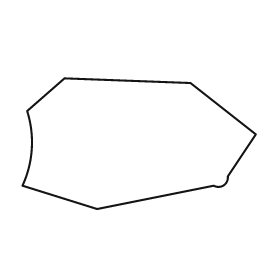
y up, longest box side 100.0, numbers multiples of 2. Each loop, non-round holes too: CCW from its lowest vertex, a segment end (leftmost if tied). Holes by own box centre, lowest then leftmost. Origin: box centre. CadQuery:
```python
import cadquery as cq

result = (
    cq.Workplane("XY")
    .moveTo(-18.0, -28.0)
    .lineTo(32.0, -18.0)
    .threePointArc((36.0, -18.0), (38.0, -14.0))
    .lineTo(50.0, 4.0)
    .lineTo(22.0, 26.0)
    .lineTo(-32.0, 28.0)
    .lineTo(-48.0, 14.0)
    .threePointArc((-46.0, -2.0), (-50.0, -18.0))
    .close()
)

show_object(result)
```